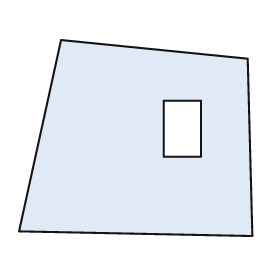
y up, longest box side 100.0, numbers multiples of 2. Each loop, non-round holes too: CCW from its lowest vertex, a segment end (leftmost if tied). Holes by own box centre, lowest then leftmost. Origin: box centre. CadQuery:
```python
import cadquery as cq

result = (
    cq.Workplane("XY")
    .moveTo(50.0, -42.0)
    .lineTo(48.0, 34.0)
    .lineTo(-32.0, 42.0)
    .lineTo(-50.0, -40.0)
    .close()
    .moveTo(12.0, -8.0)
    .lineTo(28.0, -8.0)
    .lineTo(28.0, 16.0)
    .lineTo(12.0, 16.0)
    .close()
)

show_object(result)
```